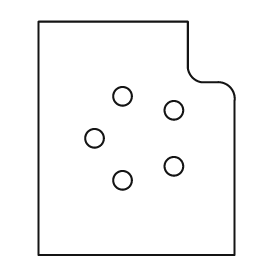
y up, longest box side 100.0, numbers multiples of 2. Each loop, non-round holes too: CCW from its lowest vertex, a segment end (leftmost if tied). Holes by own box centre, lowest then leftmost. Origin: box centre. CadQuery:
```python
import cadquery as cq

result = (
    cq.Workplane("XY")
    .moveTo(-42.0, -50.0)
    .lineTo(42.0, -50.0)
    .lineTo(42.0, 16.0)
    .threePointArc((40.0, 22.0), (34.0, 24.0))
    .lineTo(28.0, 24.0)
    .threePointArc((24.0, 26.0), (22.0, 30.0))
    .lineTo(22.0, 50.0)
    .lineTo(-42.0, 50.0)
    .close()
    .moveTo(-6.0, -18.0)
    .circle(4.0)
    .moveTo(16.0, -12.0)
    .circle(4.0)
    .moveTo(-18.0, 0.0)
    .circle(4.0)
    .moveTo(16.0, 12.0)
    .circle(4.0)
    .moveTo(-6.0, 18.0)
    .circle(4.0)
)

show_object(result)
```